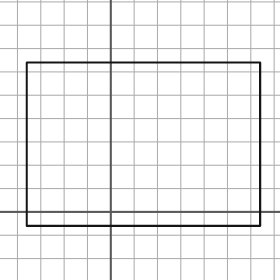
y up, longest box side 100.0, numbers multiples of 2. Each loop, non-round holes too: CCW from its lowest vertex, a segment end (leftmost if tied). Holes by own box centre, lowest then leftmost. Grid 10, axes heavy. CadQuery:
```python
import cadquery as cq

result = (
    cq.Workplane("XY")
    .moveTo(-36.0, -6.0)
    .lineTo(64.0, -6.0)
    .lineTo(64.0, 64.0)
    .lineTo(-36.0, 64.0)
    .close()
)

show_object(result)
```